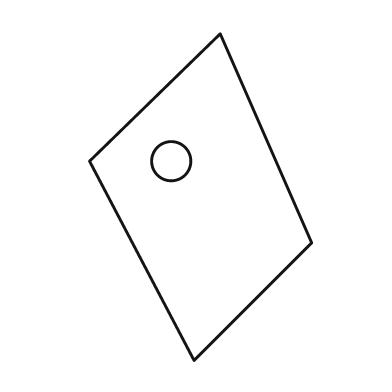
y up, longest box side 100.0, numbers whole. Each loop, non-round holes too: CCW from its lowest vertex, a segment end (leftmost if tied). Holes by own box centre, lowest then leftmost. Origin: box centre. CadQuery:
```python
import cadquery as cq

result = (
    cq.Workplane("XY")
    .moveTo(-2.0, -50.0)
    .lineTo(34.0, -14.0)
    .lineTo(6.0, 50.0)
    .lineTo(-34.0, 11.0)
    .close()
    .moveTo(-9.0, 11.0)
    .circle(6.0)
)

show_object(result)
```